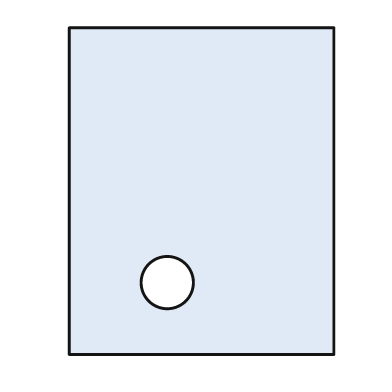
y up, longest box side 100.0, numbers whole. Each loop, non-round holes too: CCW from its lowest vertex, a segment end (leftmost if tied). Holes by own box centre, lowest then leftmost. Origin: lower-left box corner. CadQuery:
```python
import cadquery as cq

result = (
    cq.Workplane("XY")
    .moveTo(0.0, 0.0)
    .lineTo(81.0, 0.0)
    .lineTo(81.0, 100.0)
    .lineTo(0.0, 100.0)
    .close()
    .moveTo(30.0, 22.0)
    .circle(8.0)
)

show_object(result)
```